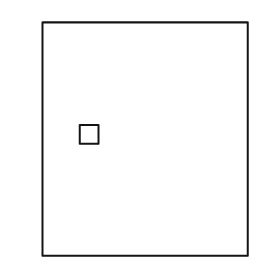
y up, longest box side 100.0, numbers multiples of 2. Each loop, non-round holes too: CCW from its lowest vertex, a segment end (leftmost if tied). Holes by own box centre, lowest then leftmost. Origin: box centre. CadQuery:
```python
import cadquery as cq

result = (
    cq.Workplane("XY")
    .moveTo(-44.0, -50.0)
    .lineTo(44.0, -50.0)
    .lineTo(44.0, 50.0)
    .lineTo(-44.0, 50.0)
    .close()
    .moveTo(-28.0, -2.0)
    .lineTo(-20.0, -2.0)
    .lineTo(-20.0, 6.0)
    .lineTo(-28.0, 6.0)
    .close()
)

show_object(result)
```